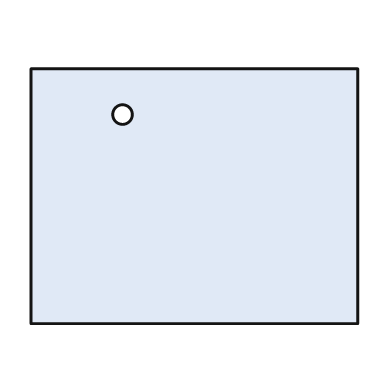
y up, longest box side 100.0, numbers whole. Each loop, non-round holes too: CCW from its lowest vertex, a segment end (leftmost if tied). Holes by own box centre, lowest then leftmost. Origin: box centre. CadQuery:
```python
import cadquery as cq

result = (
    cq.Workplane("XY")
    .moveTo(-50.0, -39.0)
    .lineTo(50.0, -39.0)
    .lineTo(50.0, 39.0)
    .lineTo(-50.0, 39.0)
    .close()
    .moveTo(-22.0, 25.0)
    .circle(3.0)
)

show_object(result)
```